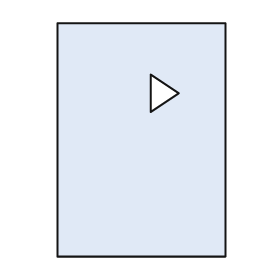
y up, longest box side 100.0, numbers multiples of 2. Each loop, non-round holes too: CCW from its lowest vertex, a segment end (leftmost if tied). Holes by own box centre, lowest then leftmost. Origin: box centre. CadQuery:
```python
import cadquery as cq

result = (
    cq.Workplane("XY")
    .moveTo(-36.0, -50.0)
    .lineTo(36.0, -50.0)
    .lineTo(36.0, 50.0)
    .lineTo(-36.0, 50.0)
    .close()
    .moveTo(4.0, 12.0)
    .lineTo(16.0, 20.0)
    .lineTo(4.0, 28.0)
    .close()
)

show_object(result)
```